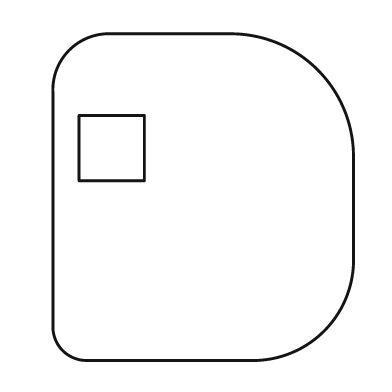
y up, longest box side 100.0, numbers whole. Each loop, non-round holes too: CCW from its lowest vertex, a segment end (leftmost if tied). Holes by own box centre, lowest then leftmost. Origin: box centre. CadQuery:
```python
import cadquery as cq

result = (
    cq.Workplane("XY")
    .moveTo(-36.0, -50.0)
    .lineTo(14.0, -50.0)
    .threePointArc((37.0, -41.0), (46.0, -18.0))
    .lineTo(46.0, 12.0)
    .threePointArc((35.0, 39.0), (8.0, 50.0))
    .lineTo(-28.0, 50.0)
    .threePointArc((-41.0, 45.0), (-46.0, 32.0))
    .lineTo(-46.0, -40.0)
    .threePointArc((-43.0, -47.0), (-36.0, -50.0))
    .close()
    .moveTo(-38.0, 5.0)
    .lineTo(-18.0, 5.0)
    .lineTo(-18.0, 25.0)
    .lineTo(-38.0, 25.0)
    .close()
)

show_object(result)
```